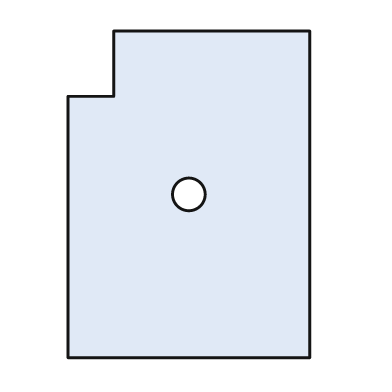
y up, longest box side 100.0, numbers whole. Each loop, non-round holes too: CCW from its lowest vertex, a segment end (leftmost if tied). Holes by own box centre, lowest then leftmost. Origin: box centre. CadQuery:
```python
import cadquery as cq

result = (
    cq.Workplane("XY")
    .moveTo(-37.0, -50.0)
    .lineTo(37.0, -50.0)
    .lineTo(37.0, 50.0)
    .lineTo(-23.0, 50.0)
    .lineTo(-23.0, 30.0)
    .lineTo(-37.0, 30.0)
    .close()
    .moveTo(0.0, 0.0)
    .circle(5.0)
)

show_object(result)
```